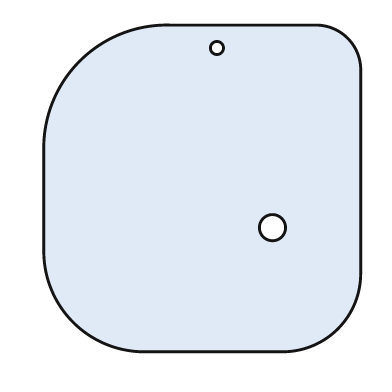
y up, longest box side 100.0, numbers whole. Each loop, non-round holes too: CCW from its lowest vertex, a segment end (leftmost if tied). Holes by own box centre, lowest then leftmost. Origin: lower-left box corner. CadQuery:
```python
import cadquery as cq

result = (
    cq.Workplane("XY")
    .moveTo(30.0, 0.0)
    .lineTo(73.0, 0.0)
    .threePointArc((90.0, 7.0), (97.0, 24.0))
    .lineTo(97.0, 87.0)
    .threePointArc((93.0, 96.0), (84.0, 100.0))
    .lineTo(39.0, 100.0)
    .threePointArc((11.0, 89.0), (0.0, 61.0))
    .lineTo(0.0, 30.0)
    .threePointArc((9.0, 9.0), (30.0, 0.0))
    .close()
    .moveTo(70.0, 38.0)
    .circle(4.0)
    .moveTo(53.0, 93.0)
    .circle(2.0)
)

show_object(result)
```